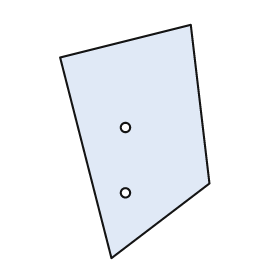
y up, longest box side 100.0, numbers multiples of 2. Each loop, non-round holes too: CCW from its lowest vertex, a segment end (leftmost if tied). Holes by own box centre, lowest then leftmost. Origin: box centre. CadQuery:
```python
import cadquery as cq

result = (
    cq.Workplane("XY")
    .moveTo(-10.0, -50.0)
    .lineTo(32.0, -18.0)
    .lineTo(24.0, 50.0)
    .lineTo(-32.0, 36.0)
    .close()
    .moveTo(-4.0, -22.0)
    .circle(2.0)
    .moveTo(-4.0, 6.0)
    .circle(2.0)
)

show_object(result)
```